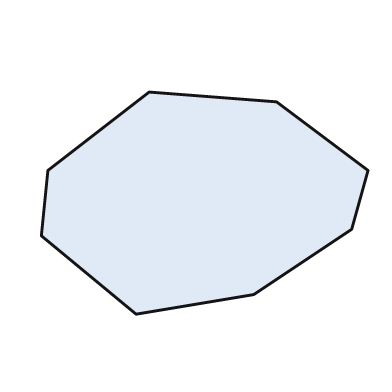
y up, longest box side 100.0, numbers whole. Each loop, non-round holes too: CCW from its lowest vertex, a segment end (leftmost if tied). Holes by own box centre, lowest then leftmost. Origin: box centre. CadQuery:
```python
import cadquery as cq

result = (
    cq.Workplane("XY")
    .moveTo(-21.0, -34.0)
    .lineTo(15.0, -28.0)
    .lineTo(45.0, -8.0)
    .lineTo(50.0, 10.0)
    .lineTo(22.0, 31.0)
    .lineTo(-17.0, 34.0)
    .lineTo(-48.0, 10.0)
    .lineTo(-50.0, -10.0)
    .close()
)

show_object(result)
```